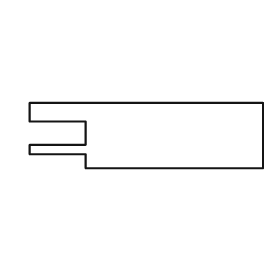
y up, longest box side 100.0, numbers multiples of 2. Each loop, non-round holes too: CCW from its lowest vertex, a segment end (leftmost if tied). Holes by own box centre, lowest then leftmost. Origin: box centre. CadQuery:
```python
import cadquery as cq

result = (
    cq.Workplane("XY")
    .moveTo(-26.0, -14.0)
    .lineTo(50.0, -14.0)
    .lineTo(50.0, 14.0)
    .lineTo(-50.0, 14.0)
    .lineTo(-50.0, 6.0)
    .lineTo(-26.0, 6.0)
    .lineTo(-26.0, -4.0)
    .lineTo(-50.0, -4.0)
    .lineTo(-50.0, -8.0)
    .lineTo(-26.0, -8.0)
    .close()
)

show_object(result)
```